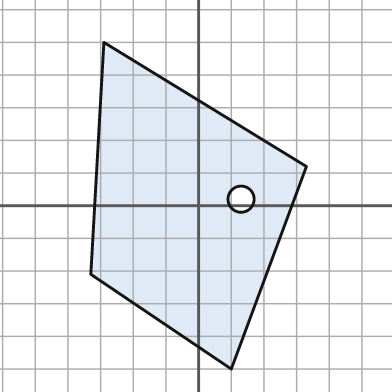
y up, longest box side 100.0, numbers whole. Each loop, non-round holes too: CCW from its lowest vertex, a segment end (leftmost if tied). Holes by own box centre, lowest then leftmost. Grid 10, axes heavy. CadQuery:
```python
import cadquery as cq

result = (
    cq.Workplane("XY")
    .moveTo(10.0, -50.0)
    .lineTo(33.0, 12.0)
    .lineTo(-29.0, 50.0)
    .lineTo(-33.0, -21.0)
    .close()
    .moveTo(13.0, 2.0)
    .circle(4.0)
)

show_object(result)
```